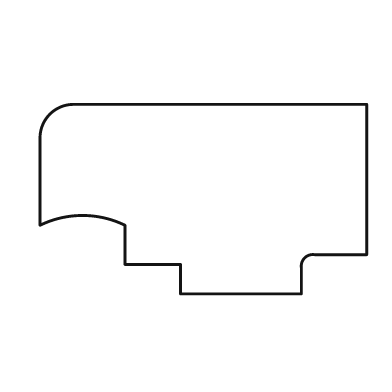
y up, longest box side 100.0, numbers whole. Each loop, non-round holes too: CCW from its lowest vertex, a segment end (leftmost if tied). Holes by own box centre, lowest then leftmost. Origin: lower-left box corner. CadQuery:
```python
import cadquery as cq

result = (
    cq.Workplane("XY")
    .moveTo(43.0, 0.0)
    .lineTo(80.0, 0.0)
    .lineTo(80.0, 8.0)
    .threePointArc((81.0, 11.0), (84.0, 12.0))
    .lineTo(100.0, 12.0)
    .lineTo(100.0, 58.0)
    .lineTo(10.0, 58.0)
    .threePointArc((3.0, 55.0), (0.0, 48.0))
    .lineTo(0.0, 21.0)
    .threePointArc((13.0, 24.0), (26.0, 21.0))
    .lineTo(26.0, 9.0)
    .lineTo(43.0, 9.0)
    .close()
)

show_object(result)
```